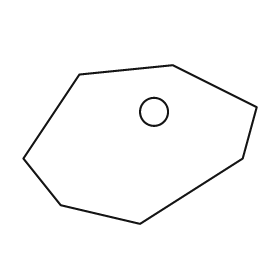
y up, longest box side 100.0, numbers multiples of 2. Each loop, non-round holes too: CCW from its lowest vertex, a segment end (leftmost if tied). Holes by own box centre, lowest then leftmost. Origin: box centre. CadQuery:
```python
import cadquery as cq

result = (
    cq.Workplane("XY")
    .moveTo(0.0, -34.0)
    .lineTo(44.0, -6.0)
    .lineTo(50.0, 16.0)
    .lineTo(14.0, 34.0)
    .lineTo(-26.0, 30.0)
    .lineTo(-50.0, -6.0)
    .lineTo(-34.0, -26.0)
    .close()
    .moveTo(6.0, 14.0)
    .circle(6.0)
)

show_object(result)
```